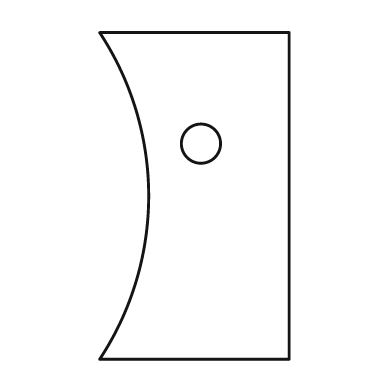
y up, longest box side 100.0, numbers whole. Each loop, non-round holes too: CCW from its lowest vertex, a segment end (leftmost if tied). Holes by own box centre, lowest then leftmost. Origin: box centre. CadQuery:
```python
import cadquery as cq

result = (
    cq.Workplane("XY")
    .moveTo(-29.0, -50.0)
    .lineTo(29.0, -50.0)
    .lineTo(29.0, 50.0)
    .lineTo(-29.0, 50.0)
    .threePointArc((-14.0, 0.0), (-29.0, -50.0))
    .close()
    .moveTo(2.0, 16.0)
    .circle(6.0)
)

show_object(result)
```